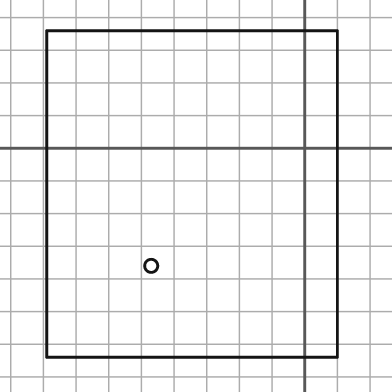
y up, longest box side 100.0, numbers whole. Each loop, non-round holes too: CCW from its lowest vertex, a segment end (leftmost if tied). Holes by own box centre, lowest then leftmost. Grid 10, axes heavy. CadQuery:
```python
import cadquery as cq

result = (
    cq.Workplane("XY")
    .moveTo(-79.0, -64.0)
    .lineTo(10.0, -64.0)
    .lineTo(10.0, 36.0)
    .lineTo(-79.0, 36.0)
    .close()
    .moveTo(-47.0, -36.0)
    .circle(2.0)
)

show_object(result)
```